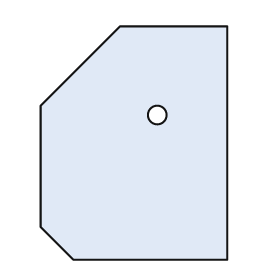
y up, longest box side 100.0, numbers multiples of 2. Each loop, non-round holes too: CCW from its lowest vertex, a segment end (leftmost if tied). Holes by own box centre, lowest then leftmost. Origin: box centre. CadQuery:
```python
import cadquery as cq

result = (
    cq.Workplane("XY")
    .moveTo(-26.0, -50.0)
    .lineTo(40.0, -50.0)
    .lineTo(40.0, 50.0)
    .lineTo(-6.0, 50.0)
    .lineTo(-40.0, 16.0)
    .lineTo(-40.0, -36.0)
    .close()
    .moveTo(10.0, 12.0)
    .circle(4.0)
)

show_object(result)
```